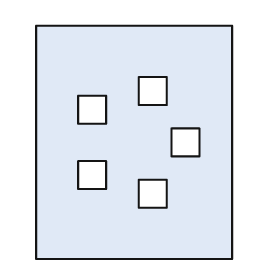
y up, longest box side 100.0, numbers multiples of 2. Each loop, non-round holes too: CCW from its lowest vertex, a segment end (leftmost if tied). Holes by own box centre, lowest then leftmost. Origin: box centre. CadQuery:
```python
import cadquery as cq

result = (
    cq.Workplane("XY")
    .moveTo(-42.0, -50.0)
    .lineTo(42.0, -50.0)
    .lineTo(42.0, 50.0)
    .lineTo(-42.0, 50.0)
    .close()
    .moveTo(2.0, -28.0)
    .lineTo(14.0, -28.0)
    .lineTo(14.0, -16.0)
    .lineTo(2.0, -16.0)
    .close()
    .moveTo(-24.0, -20.0)
    .lineTo(-12.0, -20.0)
    .lineTo(-12.0, -8.0)
    .lineTo(-24.0, -8.0)
    .close()
    .moveTo(16.0, -6.0)
    .lineTo(28.0, -6.0)
    .lineTo(28.0, 6.0)
    .lineTo(16.0, 6.0)
    .close()
    .moveTo(-24.0, 8.0)
    .lineTo(-12.0, 8.0)
    .lineTo(-12.0, 20.0)
    .lineTo(-24.0, 20.0)
    .close()
    .moveTo(2.0, 16.0)
    .lineTo(14.0, 16.0)
    .lineTo(14.0, 28.0)
    .lineTo(2.0, 28.0)
    .close()
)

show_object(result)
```